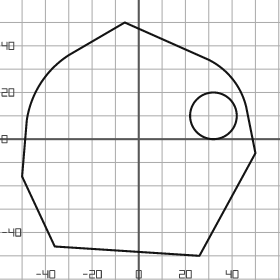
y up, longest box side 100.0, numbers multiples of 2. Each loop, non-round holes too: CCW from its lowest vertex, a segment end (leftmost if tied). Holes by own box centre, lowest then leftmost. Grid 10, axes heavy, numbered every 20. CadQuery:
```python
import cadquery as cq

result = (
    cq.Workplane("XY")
    .moveTo(26.0, -50.0)
    .lineTo(50.0, -6.0)
    .lineTo(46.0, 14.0)
    .threePointArc((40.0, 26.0), (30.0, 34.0))
    .lineTo(-6.0, 50.0)
    .lineTo(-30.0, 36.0)
    .threePointArc((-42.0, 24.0), (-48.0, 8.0))
    .lineTo(-50.0, -16.0)
    .lineTo(-36.0, -46.0)
    .close()
    .moveTo(32.0, 10.0)
    .circle(10.0)
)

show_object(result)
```